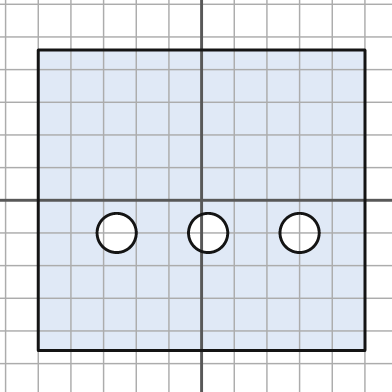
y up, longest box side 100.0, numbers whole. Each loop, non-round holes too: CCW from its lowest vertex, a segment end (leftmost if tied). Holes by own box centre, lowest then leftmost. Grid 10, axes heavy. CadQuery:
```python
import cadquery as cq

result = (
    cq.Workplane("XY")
    .moveTo(-50.0, -46.0)
    .lineTo(50.0, -46.0)
    .lineTo(50.0, 46.0)
    .lineTo(-50.0, 46.0)
    .close()
    .moveTo(-26.0, -10.0)
    .circle(6.0)
    .moveTo(2.0, -10.0)
    .circle(6.0)
    .moveTo(30.0, -10.0)
    .circle(6.0)
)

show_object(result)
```